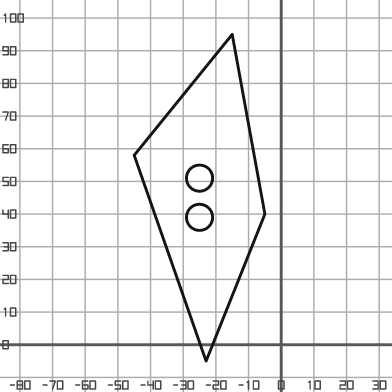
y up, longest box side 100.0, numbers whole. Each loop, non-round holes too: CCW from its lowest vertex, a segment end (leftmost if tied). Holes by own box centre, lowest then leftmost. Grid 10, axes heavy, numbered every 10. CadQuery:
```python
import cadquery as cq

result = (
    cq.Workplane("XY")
    .moveTo(-23.0, -5.0)
    .lineTo(-5.0, 40.0)
    .lineTo(-15.0, 95.0)
    .lineTo(-45.0, 58.0)
    .close()
    .moveTo(-25.0, 39.0)
    .circle(4.0)
    .moveTo(-25.0, 51.0)
    .circle(4.0)
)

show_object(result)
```